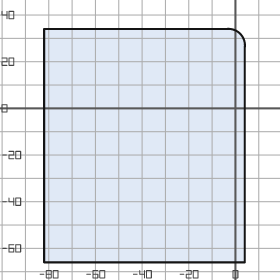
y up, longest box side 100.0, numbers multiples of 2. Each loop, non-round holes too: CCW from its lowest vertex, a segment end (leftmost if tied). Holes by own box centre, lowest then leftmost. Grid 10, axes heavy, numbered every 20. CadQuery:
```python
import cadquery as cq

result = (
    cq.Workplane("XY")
    .moveTo(-82.0, -66.0)
    .lineTo(4.0, -66.0)
    .lineTo(4.0, 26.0)
    .threePointArc((2.0, 32.0), (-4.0, 34.0))
    .lineTo(-82.0, 34.0)
    .close()
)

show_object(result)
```